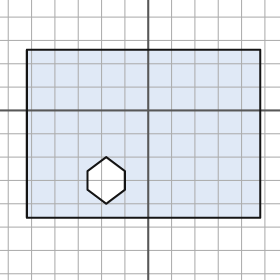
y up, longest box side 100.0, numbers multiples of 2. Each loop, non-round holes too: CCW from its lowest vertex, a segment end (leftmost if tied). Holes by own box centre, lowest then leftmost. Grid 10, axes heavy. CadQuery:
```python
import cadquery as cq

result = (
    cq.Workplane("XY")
    .moveTo(-52.0, -46.0)
    .lineTo(48.0, -46.0)
    .lineTo(48.0, 26.0)
    .lineTo(-52.0, 26.0)
    .close()
    .moveTo(-18.0, -40.0)
    .lineTo(-10.0, -34.0)
    .lineTo(-10.0, -26.0)
    .lineTo(-18.0, -20.0)
    .lineTo(-26.0, -26.0)
    .lineTo(-26.0, -34.0)
    .close()
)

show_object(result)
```